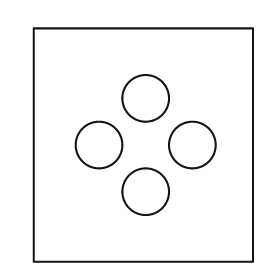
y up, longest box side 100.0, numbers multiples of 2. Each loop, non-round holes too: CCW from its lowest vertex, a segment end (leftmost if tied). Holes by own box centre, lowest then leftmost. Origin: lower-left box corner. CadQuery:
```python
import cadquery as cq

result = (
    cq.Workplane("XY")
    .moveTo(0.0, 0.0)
    .lineTo(94.0, 0.0)
    .lineTo(94.0, 100.0)
    .lineTo(0.0, 100.0)
    .close()
    .moveTo(48.0, 30.0)
    .circle(10.0)
    .moveTo(28.0, 50.0)
    .circle(10.0)
    .moveTo(68.0, 50.0)
    .circle(10.0)
    .moveTo(48.0, 70.0)
    .circle(10.0)
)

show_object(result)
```